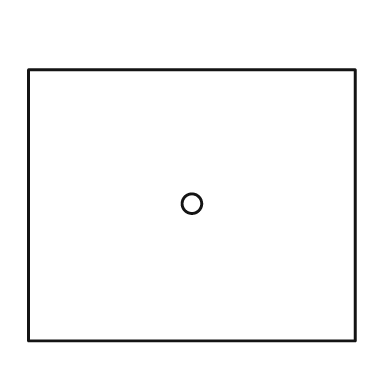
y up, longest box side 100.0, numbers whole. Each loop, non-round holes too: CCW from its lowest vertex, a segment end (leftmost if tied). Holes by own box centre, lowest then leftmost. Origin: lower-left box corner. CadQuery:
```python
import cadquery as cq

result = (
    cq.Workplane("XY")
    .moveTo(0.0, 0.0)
    .lineTo(100.0, 0.0)
    .lineTo(100.0, 83.0)
    .lineTo(0.0, 83.0)
    .close()
    .moveTo(50.0, 42.0)
    .circle(3.0)
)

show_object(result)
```